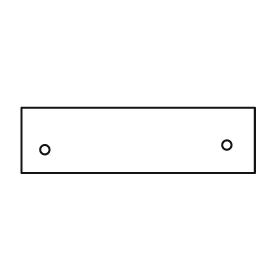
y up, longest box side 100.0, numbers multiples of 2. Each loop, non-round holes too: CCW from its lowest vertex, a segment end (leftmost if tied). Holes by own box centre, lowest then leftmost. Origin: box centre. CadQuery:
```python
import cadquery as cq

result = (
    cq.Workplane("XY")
    .moveTo(-50.0, -14.0)
    .lineTo(50.0, -14.0)
    .lineTo(50.0, 14.0)
    .lineTo(-50.0, 14.0)
    .close()
    .moveTo(-40.0, -4.0)
    .circle(2.0)
    .moveTo(38.0, -2.0)
    .circle(2.0)
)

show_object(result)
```